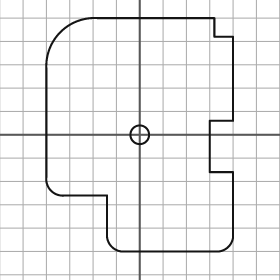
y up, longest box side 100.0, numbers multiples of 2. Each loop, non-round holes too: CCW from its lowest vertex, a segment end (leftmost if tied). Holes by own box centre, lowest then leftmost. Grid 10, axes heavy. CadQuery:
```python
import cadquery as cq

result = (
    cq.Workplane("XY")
    .moveTo(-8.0, -50.0)
    .lineTo(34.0, -50.0)
    .threePointArc((38.0, -48.0), (40.0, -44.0))
    .lineTo(40.0, -16.0)
    .lineTo(30.0, -16.0)
    .lineTo(30.0, 6.0)
    .lineTo(40.0, 6.0)
    .lineTo(40.0, 42.0)
    .lineTo(32.0, 42.0)
    .lineTo(32.0, 50.0)
    .lineTo(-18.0, 50.0)
    .threePointArc((-34.0, 44.0), (-40.0, 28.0))
    .lineTo(-40.0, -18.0)
    .threePointArc((-38.0, -24.0), (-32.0, -26.0))
    .lineTo(-14.0, -26.0)
    .lineTo(-14.0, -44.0)
    .threePointArc((-12.0, -48.0), (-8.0, -50.0))
    .close()
    .moveTo(0.0, 0.0)
    .circle(4.0)
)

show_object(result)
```